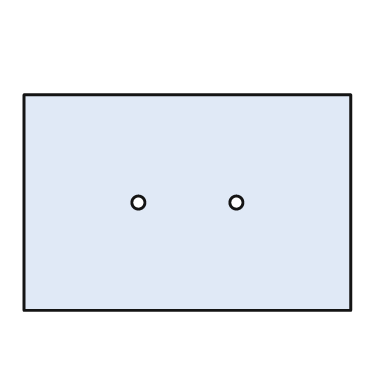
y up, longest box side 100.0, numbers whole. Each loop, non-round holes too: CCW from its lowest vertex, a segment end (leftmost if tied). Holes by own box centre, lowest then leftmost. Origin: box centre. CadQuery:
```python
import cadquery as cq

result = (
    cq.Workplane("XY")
    .moveTo(-50.0, -33.0)
    .lineTo(50.0, -33.0)
    .lineTo(50.0, 33.0)
    .lineTo(-50.0, 33.0)
    .close()
    .moveTo(-15.0, 0.0)
    .circle(2.0)
    .moveTo(15.0, 0.0)
    .circle(2.0)
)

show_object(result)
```